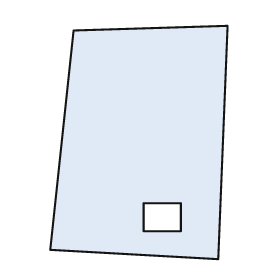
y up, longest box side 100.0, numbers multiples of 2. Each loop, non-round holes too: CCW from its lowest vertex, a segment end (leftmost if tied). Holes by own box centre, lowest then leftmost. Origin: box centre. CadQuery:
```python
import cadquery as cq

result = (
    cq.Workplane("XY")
    .moveTo(34.0, -50.0)
    .lineTo(38.0, 50.0)
    .lineTo(-28.0, 48.0)
    .lineTo(-38.0, -46.0)
    .close()
    .moveTo(2.0, -38.0)
    .lineTo(18.0, -38.0)
    .lineTo(18.0, -26.0)
    .lineTo(2.0, -26.0)
    .close()
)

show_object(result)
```